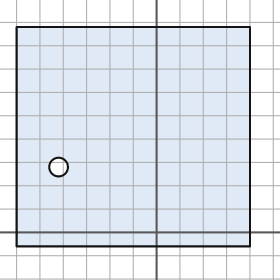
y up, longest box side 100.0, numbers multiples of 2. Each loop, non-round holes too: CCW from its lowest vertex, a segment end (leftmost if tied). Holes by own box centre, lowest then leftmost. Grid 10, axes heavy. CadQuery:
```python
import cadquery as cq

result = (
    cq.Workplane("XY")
    .moveTo(-60.0, -6.0)
    .lineTo(40.0, -6.0)
    .lineTo(40.0, 88.0)
    .lineTo(-60.0, 88.0)
    .close()
    .moveTo(-42.0, 28.0)
    .circle(4.0)
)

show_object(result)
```